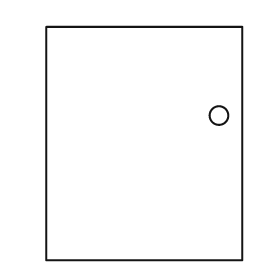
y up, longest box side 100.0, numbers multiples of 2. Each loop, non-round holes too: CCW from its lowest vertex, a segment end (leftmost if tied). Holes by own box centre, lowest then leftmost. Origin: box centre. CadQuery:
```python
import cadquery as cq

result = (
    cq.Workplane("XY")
    .moveTo(-42.0, -50.0)
    .lineTo(42.0, -50.0)
    .lineTo(42.0, 50.0)
    .lineTo(-42.0, 50.0)
    .close()
    .moveTo(32.0, 12.0)
    .circle(4.0)
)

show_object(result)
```